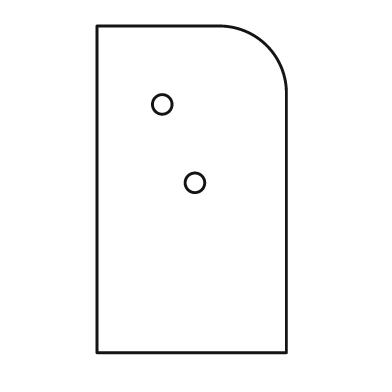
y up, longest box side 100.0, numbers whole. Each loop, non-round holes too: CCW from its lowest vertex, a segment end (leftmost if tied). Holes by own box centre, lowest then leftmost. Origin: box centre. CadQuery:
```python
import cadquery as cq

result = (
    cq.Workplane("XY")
    .moveTo(-29.0, -50.0)
    .lineTo(29.0, -50.0)
    .lineTo(29.0, 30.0)
    .threePointArc((23.0, 44.0), (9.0, 50.0))
    .lineTo(-29.0, 50.0)
    .close()
    .moveTo(1.0, 2.0)
    .circle(3.0)
    .moveTo(-9.0, 26.0)
    .circle(3.0)
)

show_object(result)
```